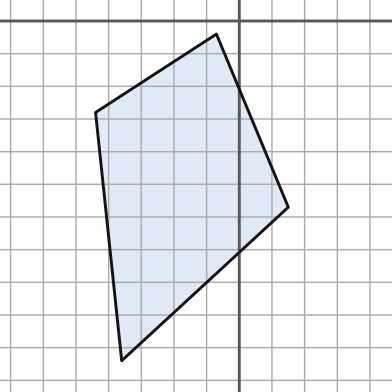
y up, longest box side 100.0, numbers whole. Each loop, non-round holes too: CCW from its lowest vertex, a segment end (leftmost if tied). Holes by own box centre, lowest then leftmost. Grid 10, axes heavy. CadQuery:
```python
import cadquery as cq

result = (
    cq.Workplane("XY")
    .moveTo(-36.0, -104.0)
    .lineTo(15.0, -57.0)
    .lineTo(-7.0, -4.0)
    .lineTo(-44.0, -28.0)
    .close()
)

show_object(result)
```